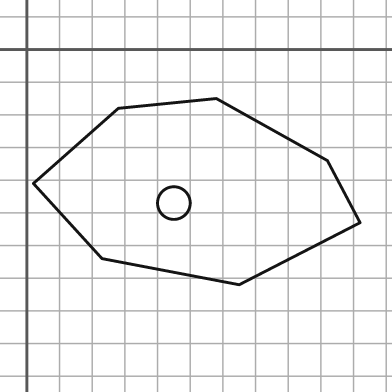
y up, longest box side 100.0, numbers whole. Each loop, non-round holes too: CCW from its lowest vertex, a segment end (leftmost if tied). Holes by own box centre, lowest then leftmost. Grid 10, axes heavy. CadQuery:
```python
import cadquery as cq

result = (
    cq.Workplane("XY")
    .moveTo(65.0, -72.0)
    .lineTo(102.0, -53.0)
    .lineTo(92.0, -34.0)
    .lineTo(58.0, -15.0)
    .lineTo(28.0, -18.0)
    .lineTo(2.0, -41.0)
    .lineTo(23.0, -64.0)
    .close()
    .moveTo(45.0, -47.0)
    .circle(5.0)
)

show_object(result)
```